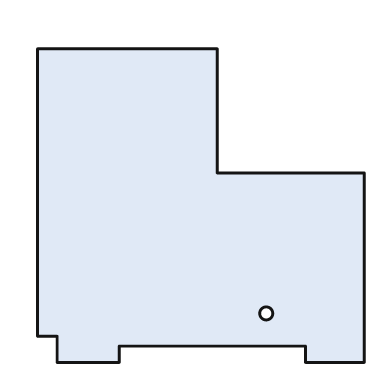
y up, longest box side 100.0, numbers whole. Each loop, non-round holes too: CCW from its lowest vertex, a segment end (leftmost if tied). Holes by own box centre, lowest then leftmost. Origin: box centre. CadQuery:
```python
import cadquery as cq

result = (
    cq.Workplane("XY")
    .moveTo(-44.0, -48.0)
    .lineTo(-25.0, -48.0)
    .lineTo(-25.0, -43.0)
    .lineTo(32.0, -43.0)
    .lineTo(32.0, -48.0)
    .lineTo(50.0, -48.0)
    .lineTo(50.0, 10.0)
    .lineTo(5.0, 10.0)
    .lineTo(5.0, 48.0)
    .lineTo(-50.0, 48.0)
    .lineTo(-50.0, -40.0)
    .lineTo(-44.0, -40.0)
    .close()
    .moveTo(20.0, -33.0)
    .circle(2.0)
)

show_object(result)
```